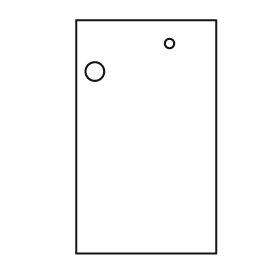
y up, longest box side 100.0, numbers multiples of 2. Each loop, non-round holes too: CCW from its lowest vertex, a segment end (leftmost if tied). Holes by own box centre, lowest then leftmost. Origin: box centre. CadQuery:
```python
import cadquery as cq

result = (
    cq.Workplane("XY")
    .moveTo(-30.0, -50.0)
    .lineTo(30.0, -50.0)
    .lineTo(30.0, 50.0)
    .lineTo(-30.0, 50.0)
    .close()
    .moveTo(-22.0, 28.0)
    .circle(4.0)
    .moveTo(10.0, 40.0)
    .circle(2.0)
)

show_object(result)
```